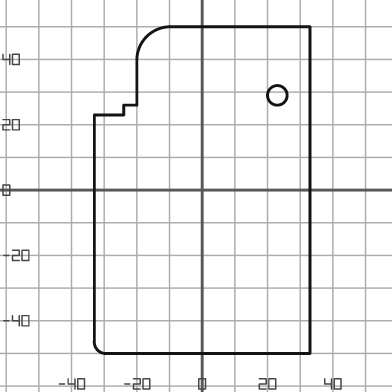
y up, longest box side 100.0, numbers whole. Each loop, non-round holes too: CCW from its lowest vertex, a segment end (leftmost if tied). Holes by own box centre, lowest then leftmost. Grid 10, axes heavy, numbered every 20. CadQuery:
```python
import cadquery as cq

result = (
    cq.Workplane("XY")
    .moveTo(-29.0, -50.0)
    .lineTo(33.0, -50.0)
    .lineTo(33.0, 50.0)
    .lineTo(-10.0, 50.0)
    .threePointArc((-17.0, 47.0), (-20.0, 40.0))
    .lineTo(-20.0, 26.0)
    .lineTo(-24.0, 26.0)
    .lineTo(-24.0, 23.0)
    .lineTo(-33.0, 23.0)
    .lineTo(-33.0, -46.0)
    .threePointArc((-32.0, -49.0), (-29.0, -50.0))
    .close()
    .moveTo(23.0, 29.0)
    .circle(3.0)
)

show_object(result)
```